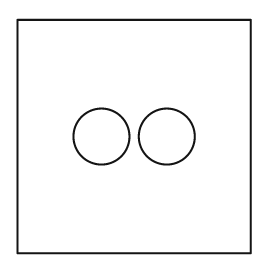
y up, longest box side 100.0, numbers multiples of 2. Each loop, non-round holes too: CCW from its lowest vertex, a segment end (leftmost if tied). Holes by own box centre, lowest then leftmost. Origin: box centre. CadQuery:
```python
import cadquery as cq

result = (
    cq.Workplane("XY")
    .moveTo(-50.0, -50.0)
    .lineTo(50.0, -50.0)
    .lineTo(50.0, 50.0)
    .lineTo(-50.0, 50.0)
    .close()
    .moveTo(-14.0, 0.0)
    .circle(12.0)
    .moveTo(14.0, 0.0)
    .circle(12.0)
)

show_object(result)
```